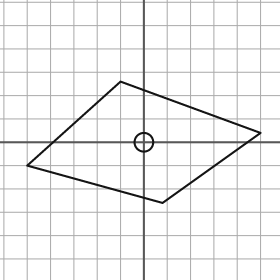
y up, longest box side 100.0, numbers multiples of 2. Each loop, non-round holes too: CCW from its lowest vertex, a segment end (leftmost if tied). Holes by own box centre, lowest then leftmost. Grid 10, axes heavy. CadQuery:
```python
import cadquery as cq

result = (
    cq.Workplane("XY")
    .moveTo(8.0, -26.0)
    .lineTo(50.0, 4.0)
    .lineTo(-10.0, 26.0)
    .lineTo(-50.0, -10.0)
    .close()
    .moveTo(0.0, 0.0)
    .circle(4.0)
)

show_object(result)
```